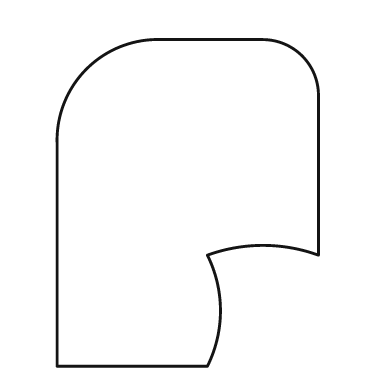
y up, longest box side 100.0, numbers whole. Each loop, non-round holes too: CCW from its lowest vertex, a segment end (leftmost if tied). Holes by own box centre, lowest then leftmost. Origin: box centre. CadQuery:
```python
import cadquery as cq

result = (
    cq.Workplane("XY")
    .moveTo(-40.0, -50.0)
    .lineTo(6.0, -50.0)
    .threePointArc((10.0, -33.0), (6.0, -16.0))
    .threePointArc((23.0, -13.0), (40.0, -16.0))
    .lineTo(40.0, 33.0)
    .threePointArc((35.0, 45.0), (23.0, 50.0))
    .lineTo(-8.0, 50.0)
    .threePointArc((-31.0, 41.0), (-40.0, 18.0))
    .close()
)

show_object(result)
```